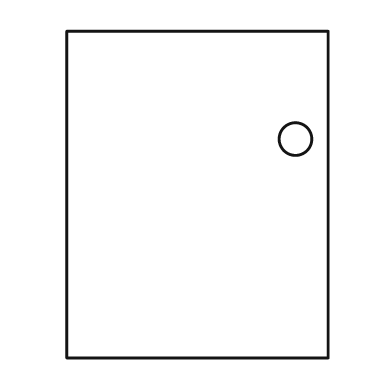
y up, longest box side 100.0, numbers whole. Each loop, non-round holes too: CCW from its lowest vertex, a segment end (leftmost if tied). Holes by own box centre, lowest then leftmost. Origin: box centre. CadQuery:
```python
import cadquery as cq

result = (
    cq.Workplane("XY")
    .moveTo(-40.0, -50.0)
    .lineTo(40.0, -50.0)
    .lineTo(40.0, 50.0)
    .lineTo(-40.0, 50.0)
    .close()
    .moveTo(30.0, 17.0)
    .circle(5.0)
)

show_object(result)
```